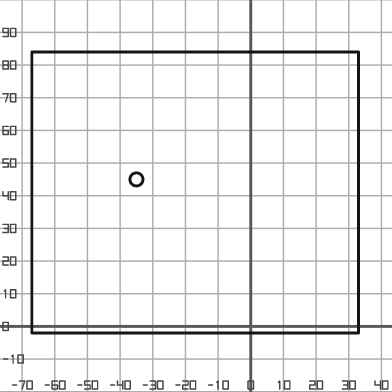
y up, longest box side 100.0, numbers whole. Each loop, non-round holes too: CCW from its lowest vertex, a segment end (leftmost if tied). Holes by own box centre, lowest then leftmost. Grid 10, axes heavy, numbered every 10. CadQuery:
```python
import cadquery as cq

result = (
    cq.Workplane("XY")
    .moveTo(-67.0, -2.0)
    .lineTo(33.0, -2.0)
    .lineTo(33.0, 84.0)
    .lineTo(-67.0, 84.0)
    .close()
    .moveTo(-35.0, 45.0)
    .circle(2.0)
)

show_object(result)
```